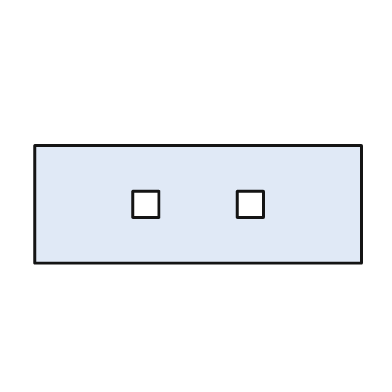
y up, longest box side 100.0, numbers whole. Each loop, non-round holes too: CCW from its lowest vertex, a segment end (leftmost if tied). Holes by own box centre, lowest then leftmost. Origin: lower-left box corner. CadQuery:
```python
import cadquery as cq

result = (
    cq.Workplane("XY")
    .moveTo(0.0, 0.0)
    .lineTo(100.0, 0.0)
    .lineTo(100.0, 36.0)
    .lineTo(0.0, 36.0)
    .close()
    .moveTo(30.0, 14.0)
    .lineTo(38.0, 14.0)
    .lineTo(38.0, 22.0)
    .lineTo(30.0, 22.0)
    .close()
    .moveTo(62.0, 14.0)
    .lineTo(70.0, 14.0)
    .lineTo(70.0, 22.0)
    .lineTo(62.0, 22.0)
    .close()
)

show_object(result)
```